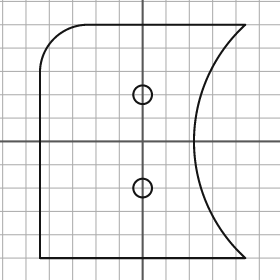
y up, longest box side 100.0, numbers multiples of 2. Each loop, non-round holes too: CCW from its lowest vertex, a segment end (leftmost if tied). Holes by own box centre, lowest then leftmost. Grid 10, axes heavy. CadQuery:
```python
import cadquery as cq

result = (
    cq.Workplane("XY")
    .moveTo(-44.0, -50.0)
    .lineTo(44.0, -50.0)
    .threePointArc((22.0, 0.0), (44.0, 50.0))
    .lineTo(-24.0, 50.0)
    .threePointArc((-38.0, 44.0), (-44.0, 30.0))
    .close()
    .moveTo(0.0, -20.0)
    .circle(4.0)
    .moveTo(0.0, 20.0)
    .circle(4.0)
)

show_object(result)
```